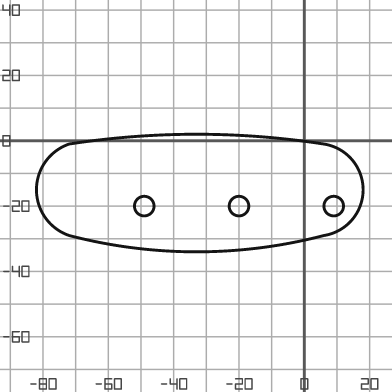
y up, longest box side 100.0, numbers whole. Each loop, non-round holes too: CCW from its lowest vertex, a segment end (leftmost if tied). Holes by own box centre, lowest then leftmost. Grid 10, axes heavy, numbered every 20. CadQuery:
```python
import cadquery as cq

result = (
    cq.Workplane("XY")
    .moveTo(-72.0, -29.0)
    .threePointArc((-33.0, -34.0), (6.0, -29.0))
    .threePointArc((18.0, -15.0), (6.0, -1.0))
    .threePointArc((-33.0, 2.0), (-72.0, -1.0))
    .threePointArc((-82.0, -15.0), (-72.0, -29.0))
    .close()
    .moveTo(-49.0, -20.0)
    .circle(3.0)
    .moveTo(-20.0, -20.0)
    .circle(3.0)
    .moveTo(9.0, -20.0)
    .circle(3.0)
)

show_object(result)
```